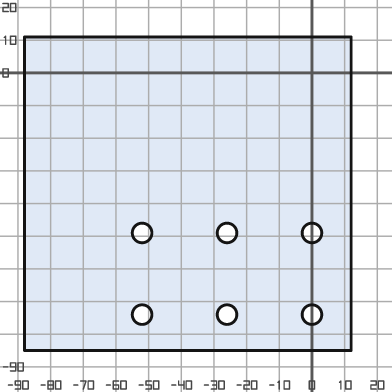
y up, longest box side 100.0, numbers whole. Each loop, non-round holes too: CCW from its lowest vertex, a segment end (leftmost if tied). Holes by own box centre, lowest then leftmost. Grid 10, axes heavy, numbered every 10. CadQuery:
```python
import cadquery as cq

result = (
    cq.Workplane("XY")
    .moveTo(-88.0, -85.0)
    .lineTo(12.0, -85.0)
    .lineTo(12.0, 11.0)
    .lineTo(-88.0, 11.0)
    .close()
    .moveTo(-52.0, -74.0)
    .circle(3.0)
    .moveTo(-26.0, -74.0)
    .circle(3.0)
    .moveTo(0.0, -74.0)
    .circle(3.0)
    .moveTo(-52.0, -49.0)
    .circle(3.0)
    .moveTo(-26.0, -49.0)
    .circle(3.0)
    .moveTo(0.0, -49.0)
    .circle(3.0)
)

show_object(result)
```